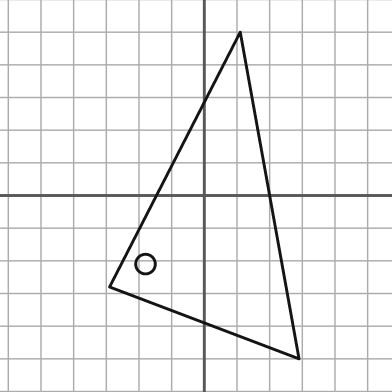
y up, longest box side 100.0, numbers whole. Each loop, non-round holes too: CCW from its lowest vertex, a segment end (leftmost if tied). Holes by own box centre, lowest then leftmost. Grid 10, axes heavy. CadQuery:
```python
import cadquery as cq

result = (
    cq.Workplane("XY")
    .moveTo(29.0, -50.0)
    .lineTo(11.0, 50.0)
    .lineTo(-29.0, -28.0)
    .close()
    .moveTo(-18.0, -21.0)
    .circle(3.0)
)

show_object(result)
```